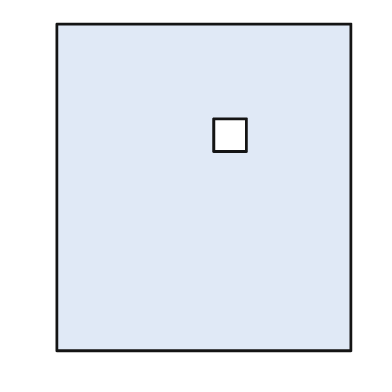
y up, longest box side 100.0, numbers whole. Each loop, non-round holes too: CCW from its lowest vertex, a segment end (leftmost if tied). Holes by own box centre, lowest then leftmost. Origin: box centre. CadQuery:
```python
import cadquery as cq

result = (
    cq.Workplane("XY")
    .moveTo(-45.0, -50.0)
    .lineTo(45.0, -50.0)
    .lineTo(45.0, 50.0)
    .lineTo(-45.0, 50.0)
    .close()
    .moveTo(3.0, 11.0)
    .lineTo(13.0, 11.0)
    .lineTo(13.0, 21.0)
    .lineTo(3.0, 21.0)
    .close()
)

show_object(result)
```